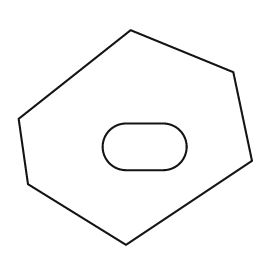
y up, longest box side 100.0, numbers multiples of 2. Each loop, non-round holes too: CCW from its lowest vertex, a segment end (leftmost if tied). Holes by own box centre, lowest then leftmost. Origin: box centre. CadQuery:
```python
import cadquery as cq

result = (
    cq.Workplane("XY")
    .moveTo(-4.0, -46.0)
    .lineTo(50.0, -10.0)
    .lineTo(42.0, 28.0)
    .lineTo(-2.0, 46.0)
    .lineTo(-50.0, 8.0)
    .lineTo(-46.0, -20.0)
    .close()
    .moveTo(-4.0, -14.0)
    .lineTo(12.0, -14.0)
    .threePointArc((22.0, -4.0), (12.0, 6.0))
    .lineTo(-4.0, 6.0)
    .threePointArc((-14.0, -4.0), (-4.0, -14.0))
    .close()
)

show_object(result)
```